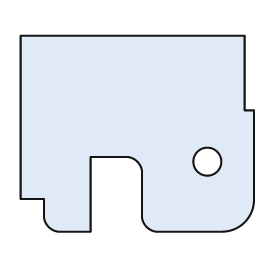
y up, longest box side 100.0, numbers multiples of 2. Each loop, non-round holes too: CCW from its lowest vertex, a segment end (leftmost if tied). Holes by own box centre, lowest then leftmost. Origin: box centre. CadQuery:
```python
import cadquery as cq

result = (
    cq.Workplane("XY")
    .moveTo(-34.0, -42.0)
    .lineTo(-20.0, -42.0)
    .lineTo(-20.0, -10.0)
    .lineTo(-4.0, -10.0)
    .threePointArc((0.0, -12.0), (2.0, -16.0))
    .lineTo(2.0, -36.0)
    .threePointArc((4.0, -40.0), (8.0, -42.0))
    .lineTo(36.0, -42.0)
    .threePointArc((46.0, -38.0), (50.0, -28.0))
    .lineTo(50.0, 10.0)
    .lineTo(46.0, 10.0)
    .lineTo(46.0, 42.0)
    .lineTo(-50.0, 42.0)
    .lineTo(-50.0, -28.0)
    .lineTo(-40.0, -28.0)
    .lineTo(-40.0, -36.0)
    .threePointArc((-38.0, -40.0), (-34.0, -42.0))
    .close()
    .moveTo(30.0, -12.0)
    .circle(6.0)
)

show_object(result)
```